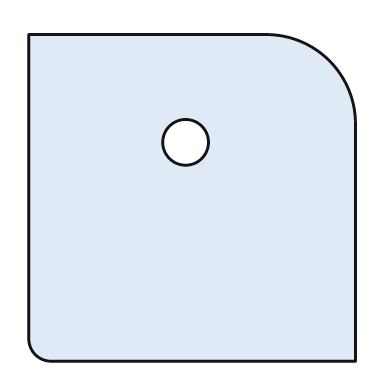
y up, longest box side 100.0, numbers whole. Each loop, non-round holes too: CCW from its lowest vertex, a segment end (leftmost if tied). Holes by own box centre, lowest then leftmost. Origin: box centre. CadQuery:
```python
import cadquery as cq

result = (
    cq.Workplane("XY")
    .moveTo(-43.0, -50.0)
    .lineTo(50.0, -50.0)
    .lineTo(50.0, 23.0)
    .threePointArc((42.0, 42.0), (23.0, 50.0))
    .lineTo(-50.0, 50.0)
    .lineTo(-50.0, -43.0)
    .threePointArc((-48.0, -48.0), (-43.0, -50.0))
    .close()
    .moveTo(-2.0, 17.0)
    .circle(7.0)
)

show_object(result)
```